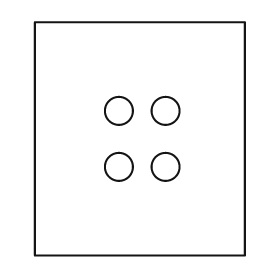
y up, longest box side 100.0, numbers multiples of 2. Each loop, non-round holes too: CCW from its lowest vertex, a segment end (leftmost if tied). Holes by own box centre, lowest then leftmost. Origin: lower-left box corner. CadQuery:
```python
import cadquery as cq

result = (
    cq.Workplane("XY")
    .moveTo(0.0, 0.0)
    .lineTo(90.0, 0.0)
    .lineTo(90.0, 100.0)
    .lineTo(0.0, 100.0)
    .close()
    .moveTo(36.0, 38.0)
    .circle(6.0)
    .moveTo(56.0, 38.0)
    .circle(6.0)
    .moveTo(36.0, 62.0)
    .circle(6.0)
    .moveTo(56.0, 62.0)
    .circle(6.0)
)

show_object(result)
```